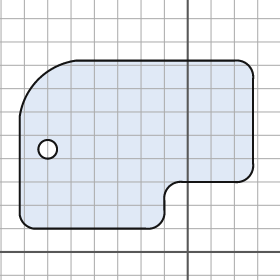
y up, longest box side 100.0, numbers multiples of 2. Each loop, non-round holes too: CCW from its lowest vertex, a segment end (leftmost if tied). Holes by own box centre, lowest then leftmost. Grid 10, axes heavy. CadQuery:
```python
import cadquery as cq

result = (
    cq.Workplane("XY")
    .moveTo(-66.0, 10.0)
    .lineTo(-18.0, 10.0)
    .threePointArc((-12.0, 12.0), (-10.0, 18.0))
    .lineTo(-10.0, 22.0)
    .threePointArc((-8.0, 28.0), (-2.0, 30.0))
    .lineTo(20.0, 30.0)
    .threePointArc((26.0, 32.0), (28.0, 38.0))
    .lineTo(28.0, 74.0)
    .threePointArc((26.0, 80.0), (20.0, 82.0))
    .lineTo(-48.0, 82.0)
    .threePointArc((-64.0, 74.0), (-72.0, 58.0))
    .lineTo(-72.0, 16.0)
    .threePointArc((-70.0, 12.0), (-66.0, 10.0))
    .close()
    .moveTo(-60.0, 44.0)
    .circle(4.0)
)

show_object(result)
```